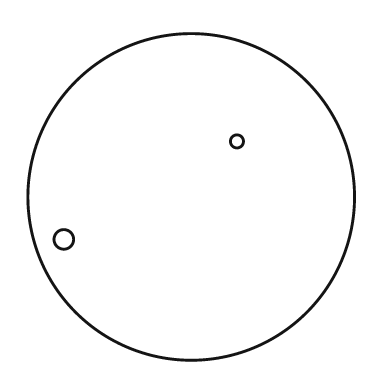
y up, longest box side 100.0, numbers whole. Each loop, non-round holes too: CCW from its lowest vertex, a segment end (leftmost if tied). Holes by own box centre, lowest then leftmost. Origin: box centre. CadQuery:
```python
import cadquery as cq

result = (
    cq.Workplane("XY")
    .moveTo(0.0, 0.0)
    .circle(50.0)
    .moveTo(-39.0, -13.0)
    .circle(3.0)
    .moveTo(14.0, 17.0)
    .circle(2.0)
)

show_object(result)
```